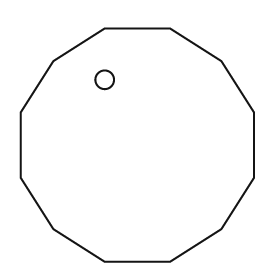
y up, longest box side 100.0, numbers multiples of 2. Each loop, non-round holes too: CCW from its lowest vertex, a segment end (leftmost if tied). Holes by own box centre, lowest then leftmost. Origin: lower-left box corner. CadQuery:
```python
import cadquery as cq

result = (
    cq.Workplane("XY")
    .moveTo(36.0, 0.0)
    .lineTo(64.0, 0.0)
    .lineTo(86.0, 14.0)
    .lineTo(100.0, 36.0)
    .lineTo(100.0, 64.0)
    .lineTo(86.0, 86.0)
    .lineTo(64.0, 100.0)
    .lineTo(36.0, 100.0)
    .lineTo(14.0, 86.0)
    .lineTo(0.0, 64.0)
    .lineTo(0.0, 36.0)
    .lineTo(14.0, 14.0)
    .close()
    .moveTo(36.0, 78.0)
    .circle(4.0)
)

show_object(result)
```